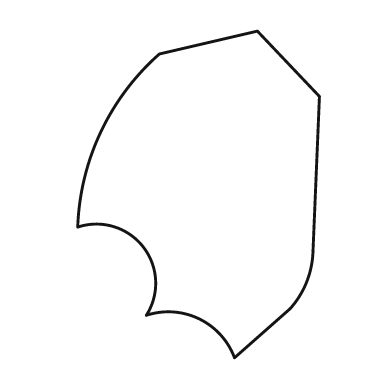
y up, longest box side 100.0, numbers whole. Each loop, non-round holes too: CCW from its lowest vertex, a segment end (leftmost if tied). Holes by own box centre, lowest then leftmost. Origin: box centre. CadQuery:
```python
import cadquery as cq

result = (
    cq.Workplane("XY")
    .moveTo(11.0, -50.0)
    .lineTo(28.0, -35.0)
    .threePointArc((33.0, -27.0), (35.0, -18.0))
    .lineTo(37.0, 30.0)
    .lineTo(18.0, 50.0)
    .lineTo(-12.0, 43.0)
    .threePointArc((-30.0, 19.0), (-37.0, -10.0))
    .threePointArc((-17.0, -16.0), (-16.0, -37.0))
    .threePointArc((0.0, -38.0), (11.0, -50.0))
    .close()
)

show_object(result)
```